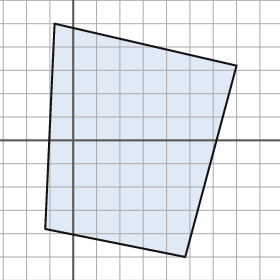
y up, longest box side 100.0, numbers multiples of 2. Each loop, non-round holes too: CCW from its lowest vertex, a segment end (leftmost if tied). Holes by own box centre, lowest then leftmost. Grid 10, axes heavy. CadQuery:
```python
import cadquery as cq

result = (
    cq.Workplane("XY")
    .moveTo(48.0, -50.0)
    .lineTo(70.0, 32.0)
    .lineTo(-8.0, 50.0)
    .lineTo(-12.0, -38.0)
    .close()
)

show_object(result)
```